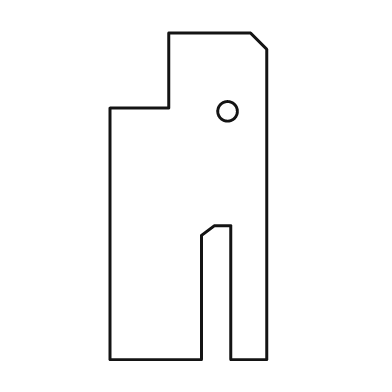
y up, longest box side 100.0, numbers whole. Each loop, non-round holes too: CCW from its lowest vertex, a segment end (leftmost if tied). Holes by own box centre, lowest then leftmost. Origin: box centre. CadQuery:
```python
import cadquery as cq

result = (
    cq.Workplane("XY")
    .moveTo(-24.0, -50.0)
    .lineTo(4.0, -50.0)
    .lineTo(4.0, -12.0)
    .lineTo(8.0, -9.0)
    .lineTo(13.0, -9.0)
    .lineTo(13.0, -50.0)
    .lineTo(24.0, -50.0)
    .lineTo(24.0, 45.0)
    .lineTo(19.0, 50.0)
    .lineTo(-6.0, 50.0)
    .lineTo(-6.0, 27.0)
    .lineTo(-24.0, 27.0)
    .close()
    .moveTo(12.0, 26.0)
    .circle(3.0)
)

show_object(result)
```